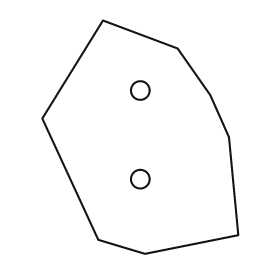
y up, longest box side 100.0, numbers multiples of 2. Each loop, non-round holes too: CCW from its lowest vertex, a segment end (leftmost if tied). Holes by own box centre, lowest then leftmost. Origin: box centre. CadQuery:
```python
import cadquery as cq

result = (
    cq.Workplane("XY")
    .moveTo(2.0, -50.0)
    .lineTo(42.0, -42.0)
    .lineTo(38.0, 0.0)
    .lineTo(30.0, 18.0)
    .lineTo(16.0, 38.0)
    .lineTo(-16.0, 50.0)
    .lineTo(-42.0, 8.0)
    .lineTo(-18.0, -44.0)
    .close()
    .moveTo(0.0, -18.0)
    .circle(4.0)
    .moveTo(0.0, 20.0)
    .circle(4.0)
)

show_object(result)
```